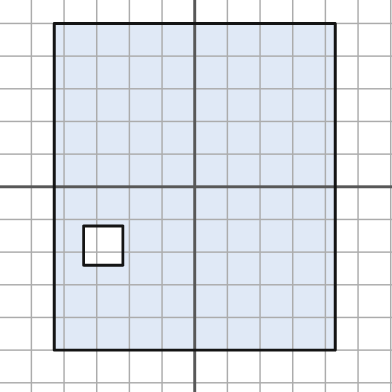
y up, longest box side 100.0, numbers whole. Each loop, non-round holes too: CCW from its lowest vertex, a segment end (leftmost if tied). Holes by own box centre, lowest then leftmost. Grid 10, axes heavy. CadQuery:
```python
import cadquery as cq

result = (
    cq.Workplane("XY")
    .moveTo(-43.0, -50.0)
    .lineTo(43.0, -50.0)
    .lineTo(43.0, 50.0)
    .lineTo(-43.0, 50.0)
    .close()
    .moveTo(-34.0, -24.0)
    .lineTo(-22.0, -24.0)
    .lineTo(-22.0, -12.0)
    .lineTo(-34.0, -12.0)
    .close()
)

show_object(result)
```